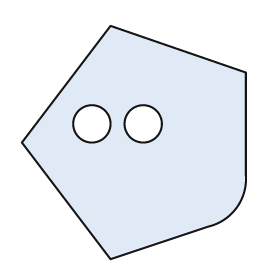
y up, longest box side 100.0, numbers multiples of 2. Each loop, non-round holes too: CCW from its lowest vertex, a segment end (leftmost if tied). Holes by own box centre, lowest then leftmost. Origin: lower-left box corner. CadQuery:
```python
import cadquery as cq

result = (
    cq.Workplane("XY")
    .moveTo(38.0, 0.0)
    .lineTo(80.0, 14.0)
    .threePointArc((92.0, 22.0), (96.0, 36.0))
    .lineTo(96.0, 80.0)
    .lineTo(38.0, 100.0)
    .lineTo(0.0, 50.0)
    .close()
    .moveTo(30.0, 58.0)
    .circle(8.0)
    .moveTo(52.0, 58.0)
    .circle(8.0)
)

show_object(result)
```